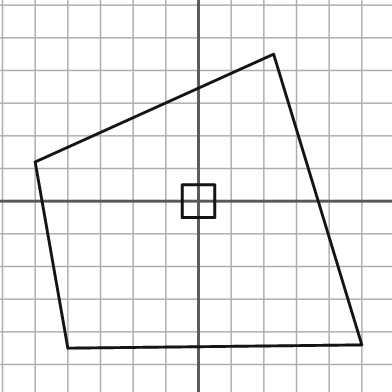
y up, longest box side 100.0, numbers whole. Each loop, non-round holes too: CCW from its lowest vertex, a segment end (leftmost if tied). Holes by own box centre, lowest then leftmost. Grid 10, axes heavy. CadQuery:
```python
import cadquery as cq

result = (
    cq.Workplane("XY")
    .moveTo(-40.0, -45.0)
    .lineTo(50.0, -44.0)
    .lineTo(23.0, 45.0)
    .lineTo(-50.0, 12.0)
    .close()
    .moveTo(-5.0, -5.0)
    .lineTo(5.0, -5.0)
    .lineTo(5.0, 5.0)
    .lineTo(-5.0, 5.0)
    .close()
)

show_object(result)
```